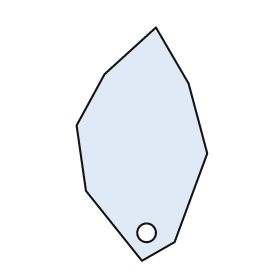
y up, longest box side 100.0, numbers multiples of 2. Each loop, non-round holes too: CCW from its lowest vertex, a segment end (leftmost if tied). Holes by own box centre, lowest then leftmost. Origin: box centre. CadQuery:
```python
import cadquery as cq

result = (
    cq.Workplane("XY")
    .moveTo(0.0, -50.0)
    .lineTo(14.0, -42.0)
    .lineTo(28.0, -4.0)
    .lineTo(20.0, 26.0)
    .lineTo(6.0, 50.0)
    .lineTo(-16.0, 30.0)
    .lineTo(-28.0, 8.0)
    .lineTo(-24.0, -20.0)
    .close()
    .moveTo(2.0, -38.0)
    .circle(4.0)
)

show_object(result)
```